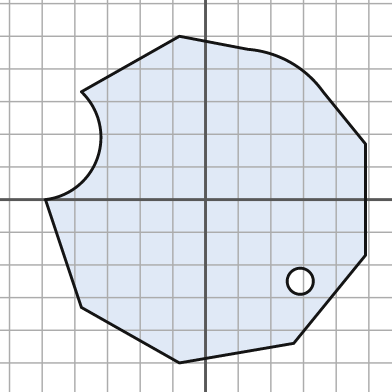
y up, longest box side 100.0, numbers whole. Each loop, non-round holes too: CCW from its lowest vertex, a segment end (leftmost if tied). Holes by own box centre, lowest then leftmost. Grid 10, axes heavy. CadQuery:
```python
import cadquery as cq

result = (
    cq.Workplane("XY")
    .moveTo(-8.0, -50.0)
    .lineTo(27.0, -44.0)
    .lineTo(49.0, -17.0)
    .lineTo(49.0, 17.0)
    .lineTo(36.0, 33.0)
    .threePointArc((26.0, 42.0), (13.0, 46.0))
    .lineTo(-8.0, 50.0)
    .lineTo(-38.0, 33.0)
    .threePointArc((-33.0, 13.0), (-49.0, 0.0))
    .lineTo(-38.0, -33.0)
    .close()
    .moveTo(29.0, -25.0)
    .circle(4.0)
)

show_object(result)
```